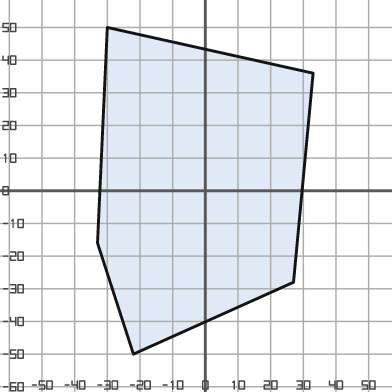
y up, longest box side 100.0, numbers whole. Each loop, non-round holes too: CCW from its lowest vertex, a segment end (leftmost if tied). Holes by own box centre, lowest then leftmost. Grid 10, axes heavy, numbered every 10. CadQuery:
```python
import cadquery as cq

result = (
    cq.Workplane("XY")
    .moveTo(-22.0, -50.0)
    .lineTo(27.0, -28.0)
    .lineTo(33.0, 36.0)
    .lineTo(-30.0, 50.0)
    .lineTo(-33.0, -16.0)
    .close()
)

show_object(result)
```